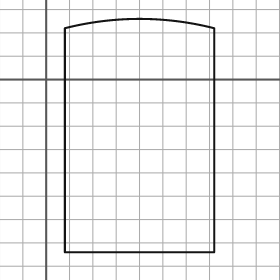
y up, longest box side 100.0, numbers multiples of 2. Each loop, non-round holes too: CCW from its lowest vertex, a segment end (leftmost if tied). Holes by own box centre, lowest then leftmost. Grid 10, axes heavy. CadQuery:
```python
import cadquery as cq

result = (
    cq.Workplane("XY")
    .moveTo(8.0, -74.0)
    .lineTo(72.0, -74.0)
    .lineTo(72.0, 22.0)
    .threePointArc((40.0, 26.0), (8.0, 22.0))
    .close()
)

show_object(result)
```